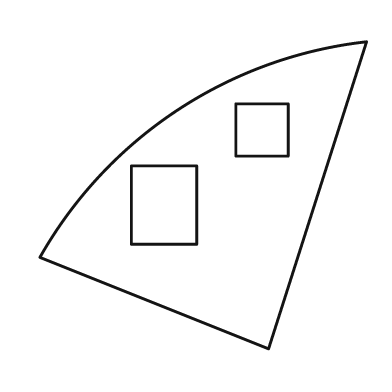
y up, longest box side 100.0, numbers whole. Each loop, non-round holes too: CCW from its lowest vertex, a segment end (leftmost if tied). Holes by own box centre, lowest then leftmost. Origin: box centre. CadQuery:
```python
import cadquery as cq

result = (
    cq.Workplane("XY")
    .moveTo(20.0, -47.0)
    .lineTo(50.0, 47.0)
    .threePointArc((-8.0, 26.0), (-50.0, -19.0))
    .close()
    .moveTo(-22.0, -15.0)
    .lineTo(-2.0, -15.0)
    .lineTo(-2.0, 9.0)
    .lineTo(-22.0, 9.0)
    .close()
    .moveTo(10.0, 12.0)
    .lineTo(26.0, 12.0)
    .lineTo(26.0, 28.0)
    .lineTo(10.0, 28.0)
    .close()
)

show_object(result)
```